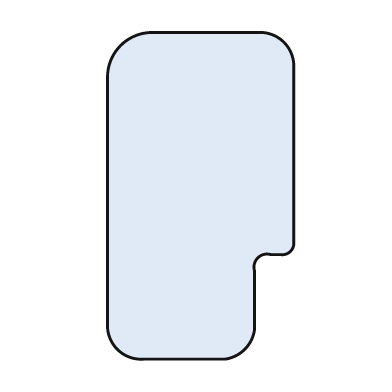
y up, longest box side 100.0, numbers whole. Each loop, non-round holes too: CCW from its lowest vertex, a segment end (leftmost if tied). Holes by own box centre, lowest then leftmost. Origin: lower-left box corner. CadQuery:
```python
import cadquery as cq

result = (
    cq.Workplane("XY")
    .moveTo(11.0, 0.0)
    .lineTo(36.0, 0.0)
    .threePointArc((42.0, 3.0), (45.0, 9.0))
    .lineTo(45.0, 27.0)
    .threePointArc((46.0, 31.0), (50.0, 32.0))
    .lineTo(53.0, 32.0)
    .threePointArc((56.0, 33.0), (57.0, 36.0))
    .lineTo(57.0, 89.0)
    .threePointArc((54.0, 97.0), (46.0, 100.0))
    .lineTo(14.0, 100.0)
    .threePointArc((4.0, 96.0), (0.0, 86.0))
    .lineTo(0.0, 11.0)
    .threePointArc((3.0, 3.0), (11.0, 0.0))
    .close()
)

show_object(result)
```